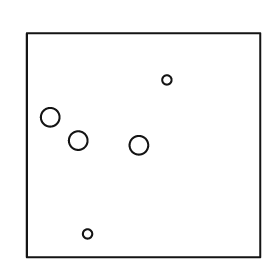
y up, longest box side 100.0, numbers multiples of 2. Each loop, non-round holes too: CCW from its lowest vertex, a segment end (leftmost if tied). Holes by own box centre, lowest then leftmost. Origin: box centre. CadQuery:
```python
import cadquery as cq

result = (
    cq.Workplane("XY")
    .moveTo(-50.0, -48.0)
    .lineTo(50.0, -48.0)
    .lineTo(50.0, 48.0)
    .lineTo(-50.0, 48.0)
    .close()
    .moveTo(-24.0, -38.0)
    .circle(2.0)
    .moveTo(-2.0, 0.0)
    .circle(4.0)
    .moveTo(-28.0, 2.0)
    .circle(4.0)
    .moveTo(-40.0, 12.0)
    .circle(4.0)
    .moveTo(10.0, 28.0)
    .circle(2.0)
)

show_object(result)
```